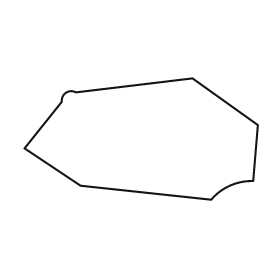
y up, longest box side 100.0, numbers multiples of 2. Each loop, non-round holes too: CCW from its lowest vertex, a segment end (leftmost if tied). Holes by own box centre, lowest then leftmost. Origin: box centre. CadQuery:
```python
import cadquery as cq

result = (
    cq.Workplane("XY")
    .moveTo(30.0, -26.0)
    .threePointArc((38.0, -20.0), (48.0, -18.0))
    .lineTo(50.0, 6.0)
    .lineTo(22.0, 26.0)
    .lineTo(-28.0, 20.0)
    .threePointArc((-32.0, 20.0), (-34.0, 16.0))
    .lineTo(-50.0, -4.0)
    .lineTo(-26.0, -20.0)
    .close()
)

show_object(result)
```